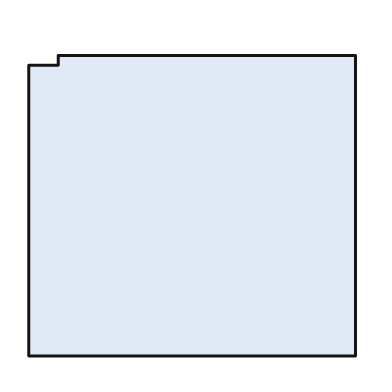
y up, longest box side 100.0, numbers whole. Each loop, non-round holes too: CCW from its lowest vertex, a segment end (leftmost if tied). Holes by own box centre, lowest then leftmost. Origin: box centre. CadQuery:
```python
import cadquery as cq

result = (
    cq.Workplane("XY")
    .moveTo(-50.0, -46.0)
    .lineTo(50.0, -46.0)
    .lineTo(50.0, 46.0)
    .lineTo(-41.0, 46.0)
    .lineTo(-41.0, 43.0)
    .lineTo(-50.0, 43.0)
    .close()
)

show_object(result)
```